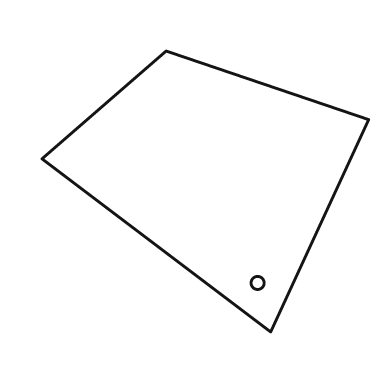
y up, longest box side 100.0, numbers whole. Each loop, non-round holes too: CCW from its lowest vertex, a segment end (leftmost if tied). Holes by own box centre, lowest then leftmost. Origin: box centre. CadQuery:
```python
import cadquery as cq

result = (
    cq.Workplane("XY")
    .moveTo(20.0, -43.0)
    .lineTo(50.0, 22.0)
    .lineTo(-12.0, 43.0)
    .lineTo(-50.0, 10.0)
    .close()
    .moveTo(16.0, -28.0)
    .circle(2.0)
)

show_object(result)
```